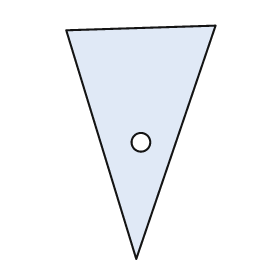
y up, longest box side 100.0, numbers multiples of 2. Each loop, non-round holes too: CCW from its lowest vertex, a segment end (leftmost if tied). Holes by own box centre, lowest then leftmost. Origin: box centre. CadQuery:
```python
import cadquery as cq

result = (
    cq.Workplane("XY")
    .moveTo(-2.0, -50.0)
    .lineTo(32.0, 50.0)
    .lineTo(-32.0, 48.0)
    .close()
    .moveTo(0.0, 0.0)
    .circle(4.0)
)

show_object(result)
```